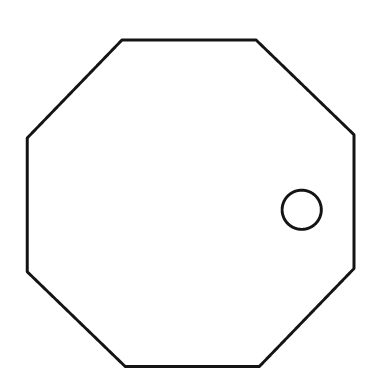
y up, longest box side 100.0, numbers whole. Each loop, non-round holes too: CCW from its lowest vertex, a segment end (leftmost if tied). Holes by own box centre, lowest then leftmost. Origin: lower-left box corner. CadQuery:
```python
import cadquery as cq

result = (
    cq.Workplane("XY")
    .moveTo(30.0, 0.0)
    .lineTo(71.0, 0.0)
    .lineTo(100.0, 30.0)
    .lineTo(100.0, 71.0)
    .lineTo(70.0, 100.0)
    .lineTo(29.0, 100.0)
    .lineTo(0.0, 70.0)
    .lineTo(0.0, 29.0)
    .close()
    .moveTo(84.0, 48.0)
    .circle(6.0)
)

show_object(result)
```